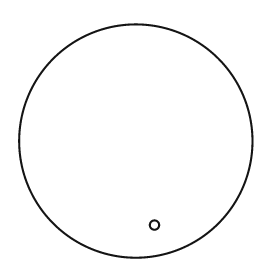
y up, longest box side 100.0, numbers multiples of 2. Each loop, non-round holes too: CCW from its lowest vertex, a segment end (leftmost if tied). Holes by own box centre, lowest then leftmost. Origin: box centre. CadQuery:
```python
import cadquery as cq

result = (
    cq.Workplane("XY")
    .moveTo(0.0, 0.0)
    .circle(50.0)
    .moveTo(8.0, -36.0)
    .circle(2.0)
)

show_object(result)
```